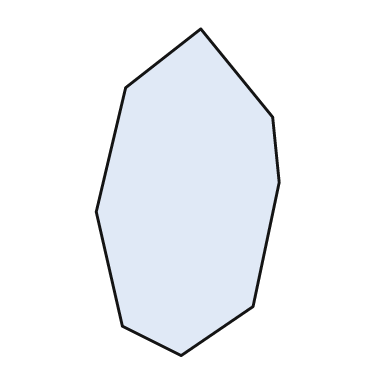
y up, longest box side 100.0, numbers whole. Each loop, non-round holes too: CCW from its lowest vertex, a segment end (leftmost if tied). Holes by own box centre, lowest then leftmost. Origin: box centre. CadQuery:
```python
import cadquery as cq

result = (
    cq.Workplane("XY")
    .moveTo(-2.0, -50.0)
    .lineTo(20.0, -35.0)
    .lineTo(28.0, 3.0)
    .lineTo(26.0, 23.0)
    .lineTo(4.0, 50.0)
    .lineTo(-19.0, 32.0)
    .lineTo(-28.0, -6.0)
    .lineTo(-20.0, -41.0)
    .close()
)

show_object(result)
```